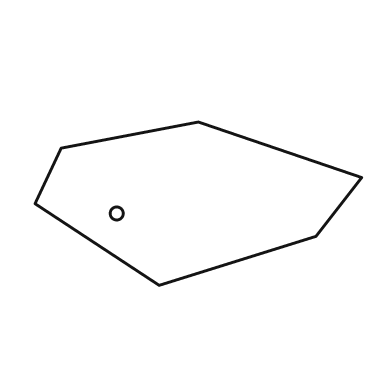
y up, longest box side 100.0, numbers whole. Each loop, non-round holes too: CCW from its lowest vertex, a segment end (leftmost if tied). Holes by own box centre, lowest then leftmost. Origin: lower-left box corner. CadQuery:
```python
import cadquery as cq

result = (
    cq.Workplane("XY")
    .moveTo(38.0, 0.0)
    .lineTo(86.0, 15.0)
    .lineTo(100.0, 33.0)
    .lineTo(50.0, 50.0)
    .lineTo(8.0, 42.0)
    .lineTo(0.0, 25.0)
    .close()
    .moveTo(25.0, 22.0)
    .circle(2.0)
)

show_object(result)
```